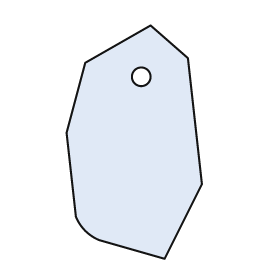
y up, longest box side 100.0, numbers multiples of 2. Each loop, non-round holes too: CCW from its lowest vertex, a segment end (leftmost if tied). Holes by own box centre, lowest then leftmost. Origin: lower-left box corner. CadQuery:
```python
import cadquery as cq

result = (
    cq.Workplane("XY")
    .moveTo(42.0, 0.0)
    .lineTo(58.0, 32.0)
    .lineTo(52.0, 86.0)
    .lineTo(36.0, 100.0)
    .lineTo(8.0, 84.0)
    .lineTo(0.0, 54.0)
    .lineTo(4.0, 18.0)
    .threePointArc((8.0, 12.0), (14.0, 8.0))
    .close()
    .moveTo(32.0, 78.0)
    .circle(4.0)
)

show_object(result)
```